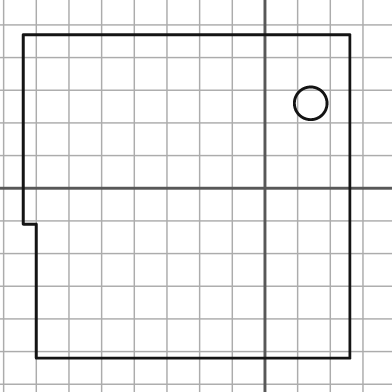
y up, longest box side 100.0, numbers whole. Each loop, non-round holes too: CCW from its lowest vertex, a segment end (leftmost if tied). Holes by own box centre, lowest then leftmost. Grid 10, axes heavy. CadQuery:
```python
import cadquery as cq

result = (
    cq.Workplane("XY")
    .moveTo(-70.0, -52.0)
    .lineTo(26.0, -52.0)
    .lineTo(26.0, 47.0)
    .lineTo(-74.0, 47.0)
    .lineTo(-74.0, -11.0)
    .lineTo(-70.0, -11.0)
    .close()
    .moveTo(14.0, 26.0)
    .circle(5.0)
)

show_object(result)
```